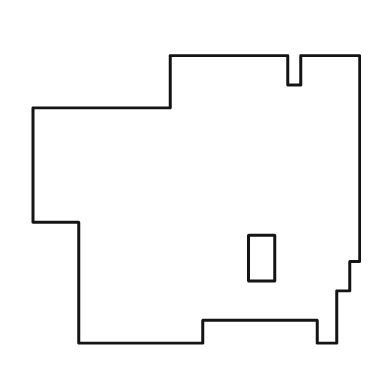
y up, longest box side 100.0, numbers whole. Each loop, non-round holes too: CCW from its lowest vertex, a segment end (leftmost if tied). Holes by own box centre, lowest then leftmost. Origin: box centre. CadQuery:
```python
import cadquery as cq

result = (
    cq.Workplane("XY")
    .moveTo(-36.0, -44.0)
    .lineTo(2.0, -44.0)
    .lineTo(2.0, -37.0)
    .lineTo(37.0, -37.0)
    .lineTo(37.0, -44.0)
    .lineTo(43.0, -44.0)
    .lineTo(43.0, -28.0)
    .lineTo(47.0, -28.0)
    .lineTo(47.0, -19.0)
    .lineTo(50.0, -19.0)
    .lineTo(50.0, 44.0)
    .lineTo(32.0, 44.0)
    .lineTo(32.0, 35.0)
    .lineTo(28.0, 35.0)
    .lineTo(28.0, 44.0)
    .lineTo(-8.0, 44.0)
    .lineTo(-8.0, 28.0)
    .lineTo(-50.0, 28.0)
    .lineTo(-50.0, -7.0)
    .lineTo(-36.0, -7.0)
    .close()
    .moveTo(16.0, -25.0)
    .lineTo(24.0, -25.0)
    .lineTo(24.0, -11.0)
    .lineTo(16.0, -11.0)
    .close()
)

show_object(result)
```